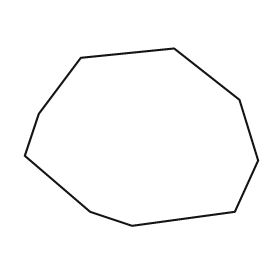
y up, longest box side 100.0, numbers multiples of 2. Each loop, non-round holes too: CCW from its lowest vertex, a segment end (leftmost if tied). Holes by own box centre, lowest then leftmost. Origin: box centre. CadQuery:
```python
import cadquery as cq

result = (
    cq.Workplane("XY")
    .moveTo(-4.0, -38.0)
    .lineTo(40.0, -32.0)
    .lineTo(50.0, -10.0)
    .lineTo(42.0, 16.0)
    .lineTo(14.0, 38.0)
    .lineTo(-26.0, 34.0)
    .lineTo(-44.0, 10.0)
    .lineTo(-50.0, -8.0)
    .lineTo(-22.0, -32.0)
    .close()
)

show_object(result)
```